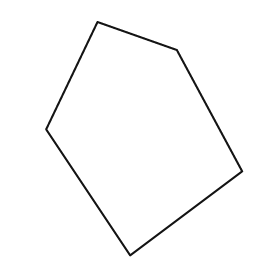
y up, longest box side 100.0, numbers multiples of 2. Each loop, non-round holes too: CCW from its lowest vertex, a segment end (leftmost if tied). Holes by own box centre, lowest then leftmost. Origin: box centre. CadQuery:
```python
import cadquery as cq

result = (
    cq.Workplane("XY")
    .moveTo(-6.0, -50.0)
    .lineTo(42.0, -14.0)
    .lineTo(14.0, 38.0)
    .lineTo(-20.0, 50.0)
    .lineTo(-42.0, 4.0)
    .close()
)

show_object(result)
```